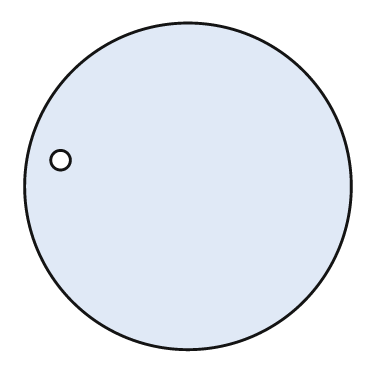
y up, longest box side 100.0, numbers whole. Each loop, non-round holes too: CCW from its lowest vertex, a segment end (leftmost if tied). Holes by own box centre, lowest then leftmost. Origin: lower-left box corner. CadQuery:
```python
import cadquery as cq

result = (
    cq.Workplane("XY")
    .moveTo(50.0, 50.0)
    .circle(50.0)
    .moveTo(11.0, 58.0)
    .circle(3.0)
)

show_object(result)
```